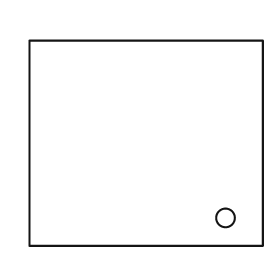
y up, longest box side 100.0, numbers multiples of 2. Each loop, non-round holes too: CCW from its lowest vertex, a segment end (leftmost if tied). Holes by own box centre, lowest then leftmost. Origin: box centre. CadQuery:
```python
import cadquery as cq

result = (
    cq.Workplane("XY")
    .moveTo(-50.0, -44.0)
    .lineTo(50.0, -44.0)
    .lineTo(50.0, 44.0)
    .lineTo(-50.0, 44.0)
    .close()
    .moveTo(34.0, -32.0)
    .circle(4.0)
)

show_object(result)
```